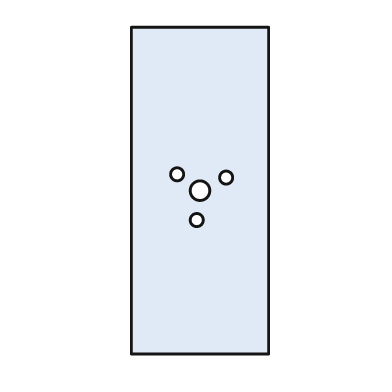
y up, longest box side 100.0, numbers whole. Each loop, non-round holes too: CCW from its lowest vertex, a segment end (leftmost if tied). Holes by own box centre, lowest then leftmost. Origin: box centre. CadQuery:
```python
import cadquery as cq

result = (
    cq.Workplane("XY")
    .moveTo(-21.0, -50.0)
    .lineTo(21.0, -50.0)
    .lineTo(21.0, 50.0)
    .lineTo(-21.0, 50.0)
    .close()
    .moveTo(-1.0, -9.0)
    .circle(2.0)
    .moveTo(0.0, 0.0)
    .circle(3.0)
    .moveTo(8.0, 4.0)
    .circle(2.0)
    .moveTo(-7.0, 5.0)
    .circle(2.0)
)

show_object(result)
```